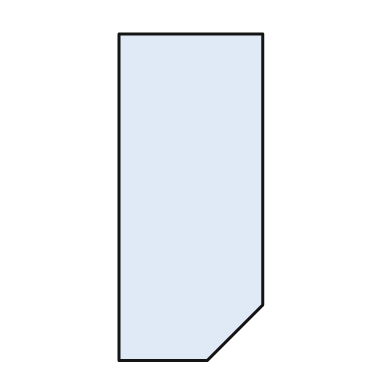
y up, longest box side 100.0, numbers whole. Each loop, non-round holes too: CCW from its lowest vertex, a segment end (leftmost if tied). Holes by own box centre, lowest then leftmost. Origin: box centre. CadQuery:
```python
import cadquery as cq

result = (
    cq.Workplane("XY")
    .moveTo(-22.0, -50.0)
    .lineTo(5.0, -50.0)
    .lineTo(22.0, -33.0)
    .lineTo(22.0, 50.0)
    .lineTo(-22.0, 50.0)
    .close()
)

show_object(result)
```